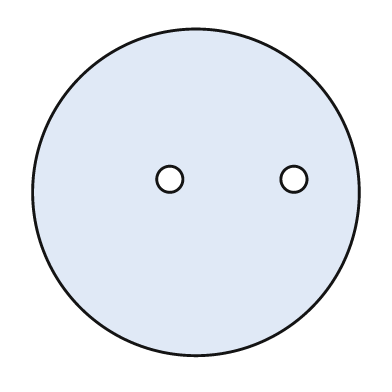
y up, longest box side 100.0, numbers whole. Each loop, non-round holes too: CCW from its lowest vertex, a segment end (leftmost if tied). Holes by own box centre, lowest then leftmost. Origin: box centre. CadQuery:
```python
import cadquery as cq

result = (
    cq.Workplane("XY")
    .moveTo(0.0, 0.0)
    .circle(50.0)
    .moveTo(-8.0, 4.0)
    .circle(4.0)
    .moveTo(30.0, 4.0)
    .circle(4.0)
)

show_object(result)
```